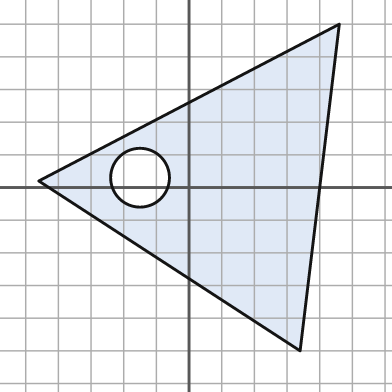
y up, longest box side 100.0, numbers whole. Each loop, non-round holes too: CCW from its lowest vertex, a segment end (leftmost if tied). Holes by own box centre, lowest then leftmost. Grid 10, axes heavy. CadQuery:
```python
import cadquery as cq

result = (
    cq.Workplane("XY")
    .moveTo(34.0, -50.0)
    .lineTo(46.0, 50.0)
    .lineTo(-46.0, 2.0)
    .close()
    .moveTo(-15.0, 3.0)
    .circle(9.0)
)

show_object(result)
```